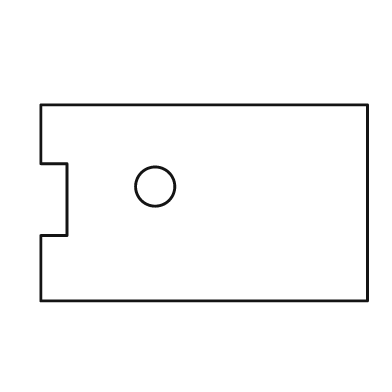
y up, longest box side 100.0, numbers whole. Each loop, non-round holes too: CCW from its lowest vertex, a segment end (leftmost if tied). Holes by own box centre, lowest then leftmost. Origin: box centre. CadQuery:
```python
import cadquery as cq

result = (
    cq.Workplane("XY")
    .moveTo(-50.0, -30.0)
    .lineTo(50.0, -30.0)
    .lineTo(50.0, 30.0)
    .lineTo(-50.0, 30.0)
    .lineTo(-50.0, 12.0)
    .lineTo(-42.0, 12.0)
    .lineTo(-42.0, -10.0)
    .lineTo(-50.0, -10.0)
    .close()
    .moveTo(-15.0, 5.0)
    .circle(6.0)
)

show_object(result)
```